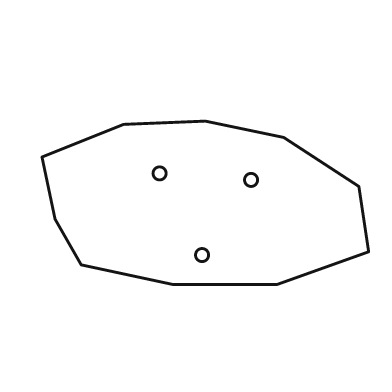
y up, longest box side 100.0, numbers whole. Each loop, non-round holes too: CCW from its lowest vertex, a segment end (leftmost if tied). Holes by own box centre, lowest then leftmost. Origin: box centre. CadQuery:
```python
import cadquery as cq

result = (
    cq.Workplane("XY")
    .moveTo(-10.0, -25.0)
    .lineTo(22.0, -25.0)
    .lineTo(50.0, -15.0)
    .lineTo(47.0, 5.0)
    .lineTo(24.0, 20.0)
    .lineTo(0.0, 25.0)
    .lineTo(-25.0, 24.0)
    .lineTo(-50.0, 14.0)
    .lineTo(-46.0, -5.0)
    .lineTo(-38.0, -19.0)
    .close()
    .moveTo(-1.0, -16.0)
    .circle(2.0)
    .moveTo(14.0, 7.0)
    .circle(2.0)
    .moveTo(-14.0, 9.0)
    .circle(2.0)
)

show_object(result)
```